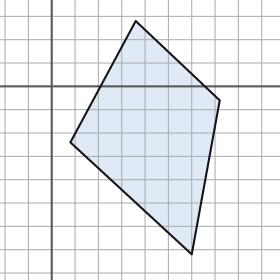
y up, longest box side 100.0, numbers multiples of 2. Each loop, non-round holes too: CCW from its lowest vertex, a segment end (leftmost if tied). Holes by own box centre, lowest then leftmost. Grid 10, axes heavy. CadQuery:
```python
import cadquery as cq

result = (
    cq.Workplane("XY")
    .moveTo(60.0, -72.0)
    .lineTo(72.0, -6.0)
    .lineTo(36.0, 28.0)
    .lineTo(8.0, -24.0)
    .close()
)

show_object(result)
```